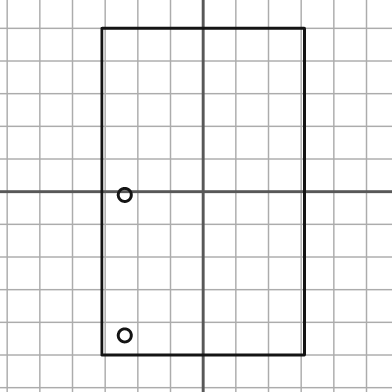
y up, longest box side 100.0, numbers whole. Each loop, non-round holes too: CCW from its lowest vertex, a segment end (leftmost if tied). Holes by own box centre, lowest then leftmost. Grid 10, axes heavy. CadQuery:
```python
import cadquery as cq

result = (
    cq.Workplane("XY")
    .moveTo(-31.0, -50.0)
    .lineTo(31.0, -50.0)
    .lineTo(31.0, 50.0)
    .lineTo(-31.0, 50.0)
    .close()
    .moveTo(-24.0, -44.0)
    .circle(2.0)
    .moveTo(-24.0, -1.0)
    .circle(2.0)
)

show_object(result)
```